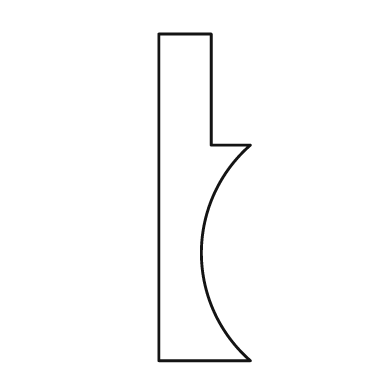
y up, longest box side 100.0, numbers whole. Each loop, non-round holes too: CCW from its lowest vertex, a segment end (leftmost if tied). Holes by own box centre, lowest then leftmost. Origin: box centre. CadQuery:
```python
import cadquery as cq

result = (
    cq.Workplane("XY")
    .moveTo(-14.0, -50.0)
    .lineTo(14.0, -50.0)
    .threePointArc((-1.0, -17.0), (14.0, 16.0))
    .lineTo(2.0, 16.0)
    .lineTo(2.0, 50.0)
    .lineTo(-14.0, 50.0)
    .close()
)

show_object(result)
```